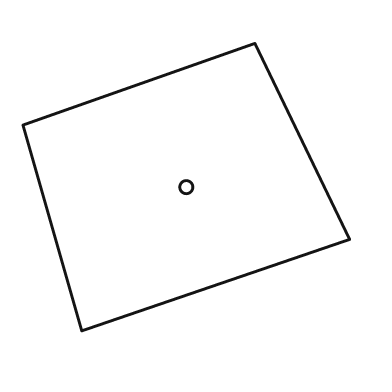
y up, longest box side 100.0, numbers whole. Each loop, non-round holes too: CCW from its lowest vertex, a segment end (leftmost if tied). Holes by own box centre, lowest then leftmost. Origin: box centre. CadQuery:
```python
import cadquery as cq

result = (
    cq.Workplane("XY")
    .moveTo(-32.0, -44.0)
    .lineTo(50.0, -16.0)
    .lineTo(21.0, 44.0)
    .lineTo(-50.0, 19.0)
    .close()
    .moveTo(0.0, 0.0)
    .circle(2.0)
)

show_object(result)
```